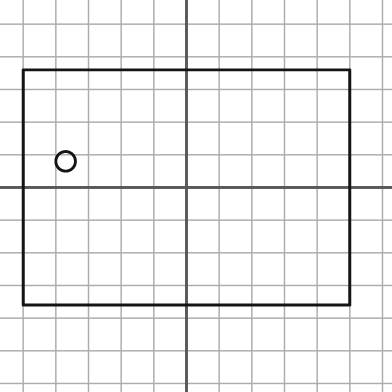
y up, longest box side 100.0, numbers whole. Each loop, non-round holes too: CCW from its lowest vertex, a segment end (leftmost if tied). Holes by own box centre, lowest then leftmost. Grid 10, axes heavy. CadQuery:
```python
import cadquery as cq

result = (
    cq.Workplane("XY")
    .moveTo(-50.0, -36.0)
    .lineTo(50.0, -36.0)
    .lineTo(50.0, 36.0)
    .lineTo(-50.0, 36.0)
    .close()
    .moveTo(-37.0, 8.0)
    .circle(3.0)
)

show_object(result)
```